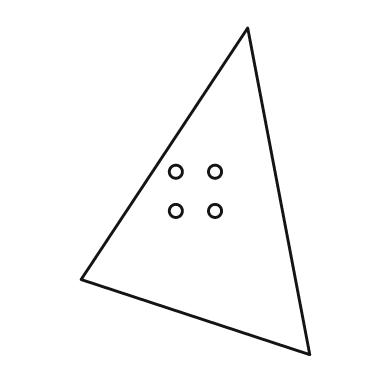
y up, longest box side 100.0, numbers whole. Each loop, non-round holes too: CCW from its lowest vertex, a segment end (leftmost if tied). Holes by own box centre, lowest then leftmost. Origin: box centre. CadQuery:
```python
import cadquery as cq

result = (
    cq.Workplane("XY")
    .moveTo(35.0, -50.0)
    .lineTo(16.0, 50.0)
    .lineTo(-35.0, -27.0)
    .close()
    .moveTo(-6.0, -6.0)
    .circle(2.0)
    .moveTo(6.0, -6.0)
    .circle(2.0)
    .moveTo(-6.0, 6.0)
    .circle(2.0)
    .moveTo(6.0, 6.0)
    .circle(2.0)
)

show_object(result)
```